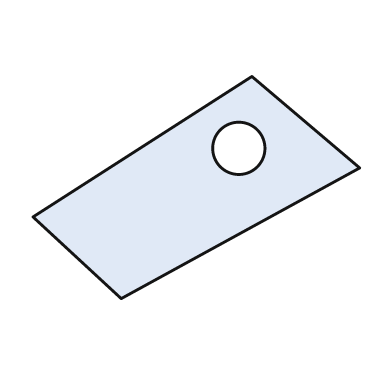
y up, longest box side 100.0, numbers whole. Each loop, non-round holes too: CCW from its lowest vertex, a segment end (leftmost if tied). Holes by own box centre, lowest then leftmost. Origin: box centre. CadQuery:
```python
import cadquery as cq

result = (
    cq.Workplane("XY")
    .moveTo(-23.0, -34.0)
    .lineTo(50.0, 6.0)
    .lineTo(17.0, 34.0)
    .lineTo(-50.0, -9.0)
    .close()
    .moveTo(13.0, 12.0)
    .circle(8.0)
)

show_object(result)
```